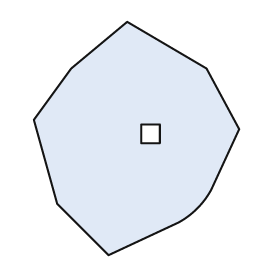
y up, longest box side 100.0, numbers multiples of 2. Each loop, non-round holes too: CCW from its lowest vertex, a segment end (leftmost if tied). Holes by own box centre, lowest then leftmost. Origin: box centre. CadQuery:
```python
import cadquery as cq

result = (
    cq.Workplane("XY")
    .moveTo(-12.0, -50.0)
    .lineTo(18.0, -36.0)
    .threePointArc((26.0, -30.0), (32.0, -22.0))
    .lineTo(44.0, 4.0)
    .lineTo(30.0, 30.0)
    .lineTo(-4.0, 50.0)
    .lineTo(-28.0, 30.0)
    .lineTo(-44.0, 8.0)
    .lineTo(-34.0, -28.0)
    .close()
    .moveTo(2.0, -2.0)
    .lineTo(10.0, -2.0)
    .lineTo(10.0, 6.0)
    .lineTo(2.0, 6.0)
    .close()
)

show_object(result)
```